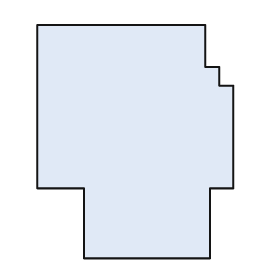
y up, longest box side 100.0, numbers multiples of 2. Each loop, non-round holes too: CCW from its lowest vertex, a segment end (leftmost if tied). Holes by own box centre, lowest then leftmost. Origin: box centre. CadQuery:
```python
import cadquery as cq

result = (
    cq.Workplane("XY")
    .moveTo(-22.0, -50.0)
    .lineTo(32.0, -50.0)
    .lineTo(32.0, -20.0)
    .lineTo(42.0, -20.0)
    .lineTo(42.0, 24.0)
    .lineTo(36.0, 24.0)
    .lineTo(36.0, 32.0)
    .lineTo(30.0, 32.0)
    .lineTo(30.0, 50.0)
    .lineTo(-42.0, 50.0)
    .lineTo(-42.0, -20.0)
    .lineTo(-22.0, -20.0)
    .close()
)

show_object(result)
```